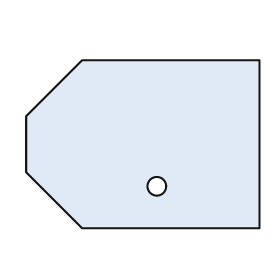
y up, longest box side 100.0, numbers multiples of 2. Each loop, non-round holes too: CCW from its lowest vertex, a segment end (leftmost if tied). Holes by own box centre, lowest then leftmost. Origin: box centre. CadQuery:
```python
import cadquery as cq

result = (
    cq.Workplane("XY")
    .moveTo(-26.0, -36.0)
    .lineTo(50.0, -36.0)
    .lineTo(50.0, 36.0)
    .lineTo(-26.0, 36.0)
    .lineTo(-50.0, 12.0)
    .lineTo(-50.0, -12.0)
    .close()
    .moveTo(6.0, -18.0)
    .circle(4.0)
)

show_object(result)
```